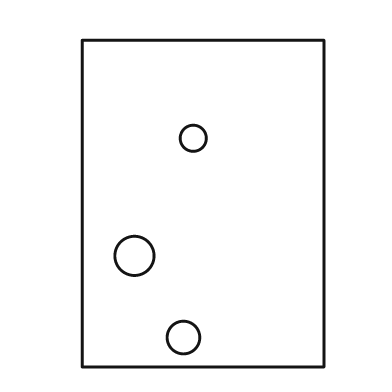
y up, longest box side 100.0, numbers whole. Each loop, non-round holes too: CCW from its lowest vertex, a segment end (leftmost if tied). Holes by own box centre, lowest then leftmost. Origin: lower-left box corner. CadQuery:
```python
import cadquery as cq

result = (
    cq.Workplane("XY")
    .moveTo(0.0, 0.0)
    .lineTo(74.0, 0.0)
    .lineTo(74.0, 100.0)
    .lineTo(0.0, 100.0)
    .close()
    .moveTo(31.0, 9.0)
    .circle(5.0)
    .moveTo(16.0, 34.0)
    .circle(6.0)
    .moveTo(34.0, 70.0)
    .circle(4.0)
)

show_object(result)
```